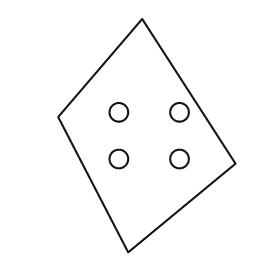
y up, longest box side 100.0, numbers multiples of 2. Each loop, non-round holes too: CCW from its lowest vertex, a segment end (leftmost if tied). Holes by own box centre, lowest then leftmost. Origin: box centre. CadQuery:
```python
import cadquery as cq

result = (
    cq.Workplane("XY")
    .moveTo(-8.0, -50.0)
    .lineTo(38.0, -12.0)
    .lineTo(-2.0, 50.0)
    .lineTo(-38.0, 8.0)
    .close()
    .moveTo(-12.0, -10.0)
    .circle(4.0)
    .moveTo(14.0, -10.0)
    .circle(4.0)
    .moveTo(-12.0, 10.0)
    .circle(4.0)
    .moveTo(14.0, 10.0)
    .circle(4.0)
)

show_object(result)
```